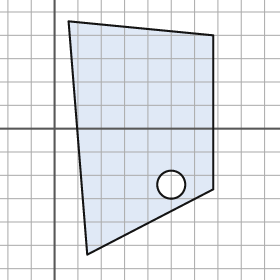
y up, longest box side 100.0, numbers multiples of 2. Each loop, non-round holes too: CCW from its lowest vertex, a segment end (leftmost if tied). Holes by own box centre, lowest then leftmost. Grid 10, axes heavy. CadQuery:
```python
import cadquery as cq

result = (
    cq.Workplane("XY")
    .moveTo(14.0, -54.0)
    .lineTo(68.0, -26.0)
    .lineTo(68.0, 40.0)
    .lineTo(6.0, 46.0)
    .close()
    .moveTo(50.0, -24.0)
    .circle(6.0)
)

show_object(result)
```